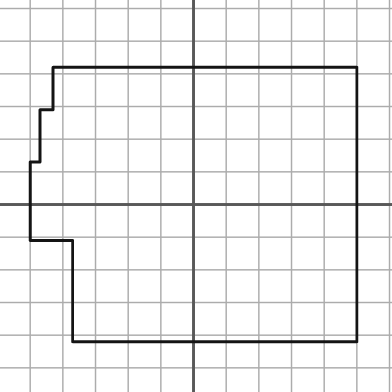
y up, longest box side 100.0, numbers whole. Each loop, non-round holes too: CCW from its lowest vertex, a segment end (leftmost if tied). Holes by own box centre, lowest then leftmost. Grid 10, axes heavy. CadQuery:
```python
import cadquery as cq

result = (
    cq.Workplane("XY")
    .moveTo(-37.0, -42.0)
    .lineTo(50.0, -42.0)
    .lineTo(50.0, 42.0)
    .lineTo(-43.0, 42.0)
    .lineTo(-43.0, 29.0)
    .lineTo(-47.0, 29.0)
    .lineTo(-47.0, 13.0)
    .lineTo(-50.0, 13.0)
    .lineTo(-50.0, -11.0)
    .lineTo(-37.0, -11.0)
    .close()
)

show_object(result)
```